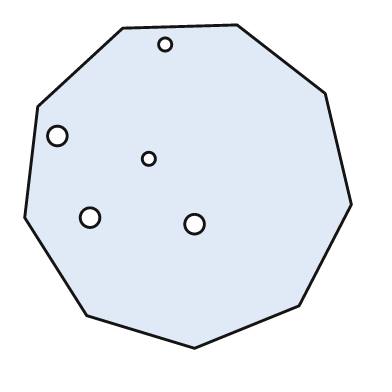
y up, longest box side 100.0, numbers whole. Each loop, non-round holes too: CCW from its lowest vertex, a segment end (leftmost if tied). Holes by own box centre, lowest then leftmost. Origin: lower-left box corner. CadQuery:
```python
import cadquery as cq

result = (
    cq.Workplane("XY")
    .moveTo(52.0, 0.0)
    .lineTo(84.0, 13.0)
    .lineTo(100.0, 44.0)
    .lineTo(92.0, 78.0)
    .lineTo(65.0, 99.0)
    .lineTo(30.0, 98.0)
    .lineTo(4.0, 74.0)
    .lineTo(0.0, 40.0)
    .lineTo(19.0, 10.0)
    .close()
    .moveTo(52.0, 38.0)
    .circle(3.0)
    .moveTo(20.0, 40.0)
    .circle(3.0)
    .moveTo(38.0, 58.0)
    .circle(2.0)
    .moveTo(10.0, 65.0)
    .circle(3.0)
    .moveTo(43.0, 93.0)
    .circle(2.0)
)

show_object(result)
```